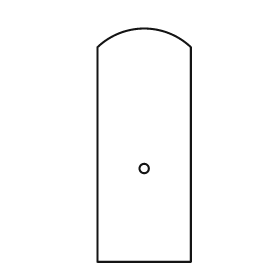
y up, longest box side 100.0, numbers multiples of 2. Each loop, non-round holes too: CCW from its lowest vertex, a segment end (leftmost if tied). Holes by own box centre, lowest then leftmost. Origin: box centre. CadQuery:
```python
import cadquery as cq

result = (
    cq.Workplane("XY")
    .moveTo(-20.0, -50.0)
    .lineTo(20.0, -50.0)
    .lineTo(20.0, 42.0)
    .threePointArc((0.0, 50.0), (-20.0, 42.0))
    .close()
    .moveTo(0.0, -10.0)
    .circle(2.0)
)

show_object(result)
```